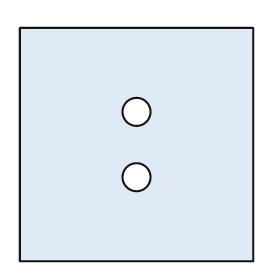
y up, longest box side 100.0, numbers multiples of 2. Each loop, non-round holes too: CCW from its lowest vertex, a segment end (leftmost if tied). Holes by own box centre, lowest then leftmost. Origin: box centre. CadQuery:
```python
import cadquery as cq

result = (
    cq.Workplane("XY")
    .moveTo(-50.0, -50.0)
    .lineTo(50.0, -50.0)
    .lineTo(50.0, 50.0)
    .lineTo(-50.0, 50.0)
    .close()
    .moveTo(0.0, -14.0)
    .circle(6.0)
    .moveTo(0.0, 14.0)
    .circle(6.0)
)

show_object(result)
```